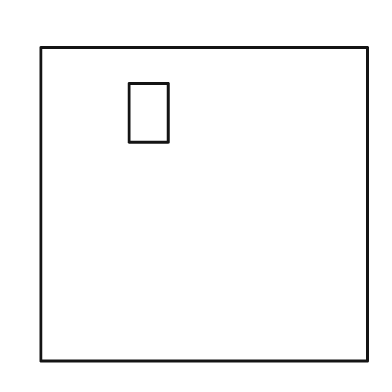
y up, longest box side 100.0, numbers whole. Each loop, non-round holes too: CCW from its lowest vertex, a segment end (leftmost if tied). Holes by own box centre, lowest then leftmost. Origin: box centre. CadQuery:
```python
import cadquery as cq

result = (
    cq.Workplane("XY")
    .moveTo(-50.0, -48.0)
    .lineTo(50.0, -48.0)
    .lineTo(50.0, 48.0)
    .lineTo(-50.0, 48.0)
    .close()
    .moveTo(-23.0, 19.0)
    .lineTo(-11.0, 19.0)
    .lineTo(-11.0, 37.0)
    .lineTo(-23.0, 37.0)
    .close()
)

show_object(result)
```